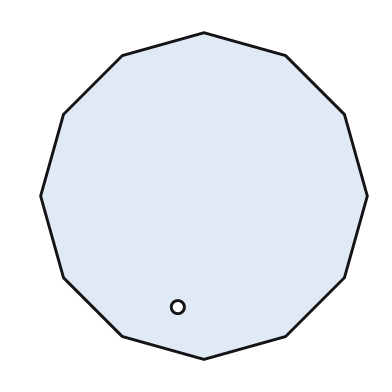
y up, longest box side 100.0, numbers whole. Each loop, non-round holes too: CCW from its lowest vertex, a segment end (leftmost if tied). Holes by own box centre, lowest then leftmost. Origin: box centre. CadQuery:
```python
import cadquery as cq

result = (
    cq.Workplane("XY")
    .moveTo(0.0, -50.0)
    .lineTo(25.0, -43.0)
    .lineTo(43.0, -25.0)
    .lineTo(50.0, 0.0)
    .lineTo(43.0, 25.0)
    .lineTo(25.0, 43.0)
    .lineTo(0.0, 50.0)
    .lineTo(-25.0, 43.0)
    .lineTo(-43.0, 25.0)
    .lineTo(-50.0, 0.0)
    .lineTo(-43.0, -25.0)
    .lineTo(-25.0, -43.0)
    .close()
    .moveTo(-8.0, -34.0)
    .circle(2.0)
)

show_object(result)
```